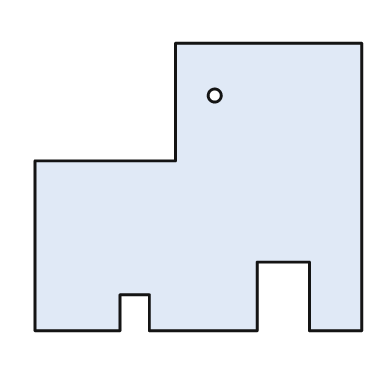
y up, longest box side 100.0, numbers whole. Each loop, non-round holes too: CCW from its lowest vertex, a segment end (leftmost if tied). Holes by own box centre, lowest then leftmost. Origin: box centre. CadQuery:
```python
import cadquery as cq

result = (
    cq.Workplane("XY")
    .moveTo(-50.0, -44.0)
    .lineTo(-24.0, -44.0)
    .lineTo(-24.0, -33.0)
    .lineTo(-15.0, -33.0)
    .lineTo(-15.0, -44.0)
    .lineTo(18.0, -44.0)
    .lineTo(18.0, -23.0)
    .lineTo(34.0, -23.0)
    .lineTo(34.0, -44.0)
    .lineTo(50.0, -44.0)
    .lineTo(50.0, 44.0)
    .lineTo(-7.0, 44.0)
    .lineTo(-7.0, 8.0)
    .lineTo(-50.0, 8.0)
    .close()
    .moveTo(5.0, 28.0)
    .circle(2.0)
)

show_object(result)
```